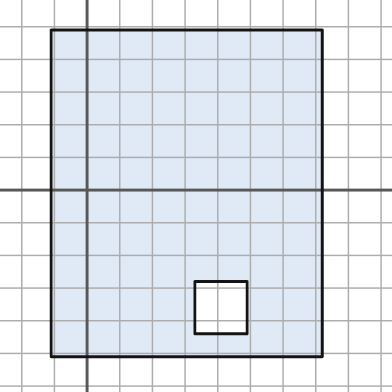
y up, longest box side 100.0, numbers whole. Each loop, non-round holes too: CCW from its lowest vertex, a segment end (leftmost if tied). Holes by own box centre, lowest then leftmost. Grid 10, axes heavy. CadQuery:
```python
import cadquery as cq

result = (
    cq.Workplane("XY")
    .moveTo(-11.0, -51.0)
    .lineTo(72.0, -51.0)
    .lineTo(72.0, 49.0)
    .lineTo(-11.0, 49.0)
    .close()
    .moveTo(33.0, -44.0)
    .lineTo(49.0, -44.0)
    .lineTo(49.0, -28.0)
    .lineTo(33.0, -28.0)
    .close()
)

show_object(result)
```